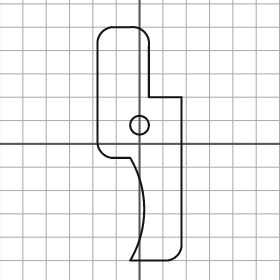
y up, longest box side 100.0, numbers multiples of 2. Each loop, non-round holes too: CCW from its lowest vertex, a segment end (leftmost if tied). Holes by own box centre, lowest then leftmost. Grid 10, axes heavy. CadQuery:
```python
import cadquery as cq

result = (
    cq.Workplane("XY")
    .moveTo(-4.0, -50.0)
    .lineTo(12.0, -50.0)
    .threePointArc((16.0, -48.0), (18.0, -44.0))
    .lineTo(18.0, 20.0)
    .lineTo(4.0, 20.0)
    .lineTo(4.0, 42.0)
    .threePointArc((2.0, 48.0), (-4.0, 50.0))
    .lineTo(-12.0, 50.0)
    .threePointArc((-16.0, 48.0), (-18.0, 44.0))
    .lineTo(-18.0, 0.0)
    .threePointArc((-16.0, -4.0), (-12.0, -6.0))
    .lineTo(-4.0, -6.0)
    .threePointArc((2.0, -28.0), (-4.0, -50.0))
    .close()
    .moveTo(0.0, 8.0)
    .circle(4.0)
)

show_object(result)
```